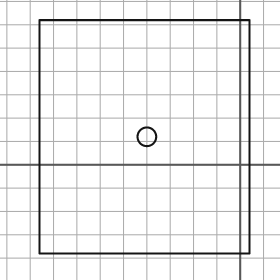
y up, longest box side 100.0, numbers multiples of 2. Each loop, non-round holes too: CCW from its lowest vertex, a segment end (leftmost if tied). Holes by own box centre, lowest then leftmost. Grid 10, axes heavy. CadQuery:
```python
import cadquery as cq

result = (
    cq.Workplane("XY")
    .moveTo(-86.0, -38.0)
    .lineTo(4.0, -38.0)
    .lineTo(4.0, 62.0)
    .lineTo(-86.0, 62.0)
    .close()
    .moveTo(-40.0, 12.0)
    .circle(4.0)
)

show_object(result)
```